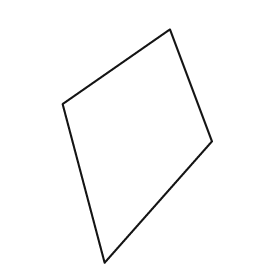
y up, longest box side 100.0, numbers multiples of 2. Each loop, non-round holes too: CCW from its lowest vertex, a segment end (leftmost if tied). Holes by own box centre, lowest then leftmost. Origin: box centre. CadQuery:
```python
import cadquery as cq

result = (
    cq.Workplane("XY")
    .moveTo(-14.0, -50.0)
    .lineTo(32.0, 2.0)
    .lineTo(14.0, 50.0)
    .lineTo(-32.0, 18.0)
    .close()
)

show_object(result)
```